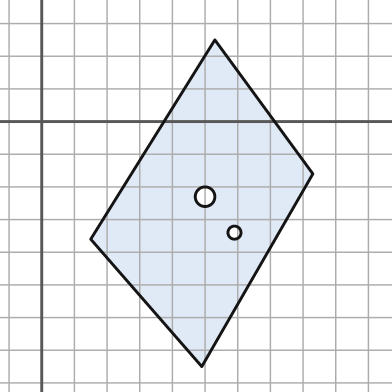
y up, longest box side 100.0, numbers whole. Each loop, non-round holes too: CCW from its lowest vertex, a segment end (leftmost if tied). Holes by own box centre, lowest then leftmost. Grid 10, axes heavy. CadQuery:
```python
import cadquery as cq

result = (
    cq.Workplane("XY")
    .moveTo(49.0, -75.0)
    .lineTo(83.0, -16.0)
    .lineTo(53.0, 25.0)
    .lineTo(15.0, -36.0)
    .close()
    .moveTo(59.0, -34.0)
    .circle(2.0)
    .moveTo(50.0, -23.0)
    .circle(3.0)
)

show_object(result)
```